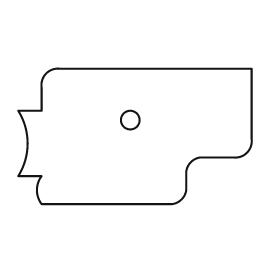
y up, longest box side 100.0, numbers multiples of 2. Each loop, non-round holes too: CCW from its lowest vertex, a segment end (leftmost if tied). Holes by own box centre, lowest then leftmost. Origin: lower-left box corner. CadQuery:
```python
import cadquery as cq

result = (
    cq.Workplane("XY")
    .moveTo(10.0, 0.0)
    .lineTo(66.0, 0.0)
    .threePointArc((70.0, 2.0), (72.0, 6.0))
    .lineTo(72.0, 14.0)
    .threePointArc((74.0, 18.0), (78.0, 20.0))
    .lineTo(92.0, 20.0)
    .threePointArc((98.0, 22.0), (100.0, 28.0))
    .lineTo(100.0, 58.0)
    .lineTo(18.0, 58.0)
    .threePointArc((12.0, 56.0), (10.0, 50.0))
    .lineTo(10.0, 40.0)
    .lineTo(0.0, 40.0)
    .threePointArc((4.0, 26.0), (0.0, 12.0))
    .lineTo(10.0, 12.0)
    .threePointArc((8.0, 6.0), (10.0, 0.0))
    .close()
    .moveTo(48.0, 36.0)
    .circle(4.0)
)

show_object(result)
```